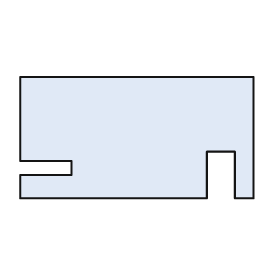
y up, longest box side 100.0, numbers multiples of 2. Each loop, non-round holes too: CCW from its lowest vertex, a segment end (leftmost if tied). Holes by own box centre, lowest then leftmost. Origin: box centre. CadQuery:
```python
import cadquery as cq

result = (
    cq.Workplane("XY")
    .moveTo(-50.0, -26.0)
    .lineTo(30.0, -26.0)
    .lineTo(30.0, -6.0)
    .lineTo(42.0, -6.0)
    .lineTo(42.0, -26.0)
    .lineTo(50.0, -26.0)
    .lineTo(50.0, 26.0)
    .lineTo(-50.0, 26.0)
    .lineTo(-50.0, -10.0)
    .lineTo(-28.0, -10.0)
    .lineTo(-28.0, -16.0)
    .lineTo(-50.0, -16.0)
    .close()
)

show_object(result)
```